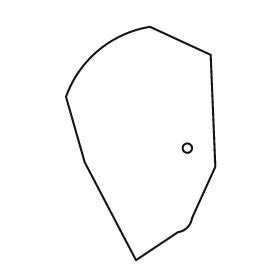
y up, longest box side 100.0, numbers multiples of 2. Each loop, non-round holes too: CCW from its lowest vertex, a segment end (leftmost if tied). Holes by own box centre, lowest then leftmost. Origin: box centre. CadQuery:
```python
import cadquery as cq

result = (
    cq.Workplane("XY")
    .moveTo(-2.0, -50.0)
    .lineTo(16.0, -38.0)
    .threePointArc((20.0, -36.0), (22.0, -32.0))
    .lineTo(32.0, -10.0)
    .lineTo(30.0, 38.0)
    .lineTo(4.0, 50.0)
    .threePointArc((-18.0, 40.0), (-32.0, 20.0))
    .lineTo(-24.0, -8.0)
    .close()
    .moveTo(20.0, -2.0)
    .circle(2.0)
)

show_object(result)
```